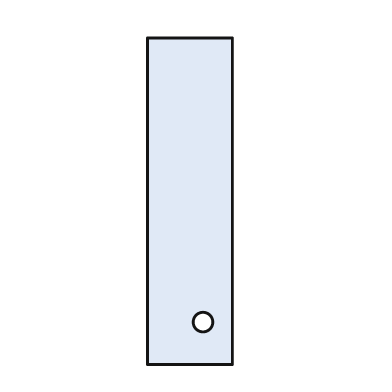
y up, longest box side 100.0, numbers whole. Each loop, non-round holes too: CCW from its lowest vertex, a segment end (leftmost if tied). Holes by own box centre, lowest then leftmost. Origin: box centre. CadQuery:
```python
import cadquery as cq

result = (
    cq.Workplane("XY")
    .moveTo(-13.0, -50.0)
    .lineTo(13.0, -50.0)
    .lineTo(13.0, 50.0)
    .lineTo(-13.0, 50.0)
    .close()
    .moveTo(4.0, -37.0)
    .circle(3.0)
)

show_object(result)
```